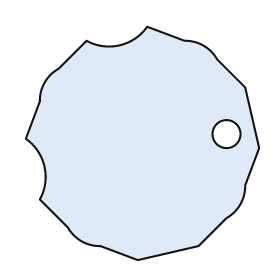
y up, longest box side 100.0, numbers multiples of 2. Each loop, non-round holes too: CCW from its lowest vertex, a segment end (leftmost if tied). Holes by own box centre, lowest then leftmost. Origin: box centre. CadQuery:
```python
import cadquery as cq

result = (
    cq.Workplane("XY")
    .moveTo(-2.0, -50.0)
    .lineTo(24.0, -44.0)
    .lineTo(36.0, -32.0)
    .threePointArc((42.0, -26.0), (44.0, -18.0))
    .lineTo(50.0, -2.0)
    .lineTo(44.0, 24.0)
    .lineTo(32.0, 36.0)
    .threePointArc((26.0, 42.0), (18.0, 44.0))
    .lineTo(2.0, 50.0)
    .threePointArc((-10.0, 42.0), (-24.0, 44.0))
    .lineTo(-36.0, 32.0)
    .threePointArc((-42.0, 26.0), (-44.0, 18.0))
    .lineTo(-50.0, 2.0)
    .threePointArc((-42.0, -10.0), (-44.0, -24.0))
    .lineTo(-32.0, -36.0)
    .threePointArc((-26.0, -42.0), (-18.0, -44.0))
    .close()
    .moveTo(36.0, 4.0)
    .circle(6.0)
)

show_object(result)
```